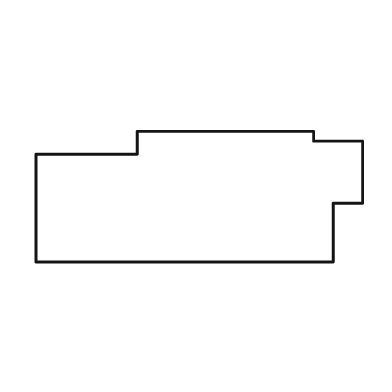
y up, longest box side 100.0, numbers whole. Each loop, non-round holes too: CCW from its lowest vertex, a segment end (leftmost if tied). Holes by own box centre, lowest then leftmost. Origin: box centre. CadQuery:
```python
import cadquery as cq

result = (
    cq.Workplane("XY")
    .moveTo(-50.0, -20.0)
    .lineTo(41.0, -20.0)
    .lineTo(41.0, -2.0)
    .lineTo(50.0, -2.0)
    .lineTo(50.0, 17.0)
    .lineTo(35.0, 17.0)
    .lineTo(35.0, 20.0)
    .lineTo(-19.0, 20.0)
    .lineTo(-19.0, 13.0)
    .lineTo(-50.0, 13.0)
    .close()
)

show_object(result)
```